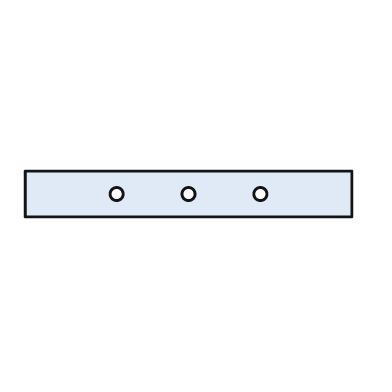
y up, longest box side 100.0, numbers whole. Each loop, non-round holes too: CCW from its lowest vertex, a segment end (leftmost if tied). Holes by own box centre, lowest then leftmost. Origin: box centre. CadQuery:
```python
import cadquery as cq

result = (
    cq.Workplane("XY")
    .moveTo(-50.0, -7.0)
    .lineTo(50.0, -7.0)
    .lineTo(50.0, 7.0)
    .lineTo(-50.0, 7.0)
    .close()
    .moveTo(-22.0, 0.0)
    .circle(2.0)
    .moveTo(0.0, 0.0)
    .circle(2.0)
    .moveTo(22.0, 0.0)
    .circle(2.0)
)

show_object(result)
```